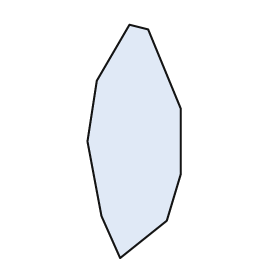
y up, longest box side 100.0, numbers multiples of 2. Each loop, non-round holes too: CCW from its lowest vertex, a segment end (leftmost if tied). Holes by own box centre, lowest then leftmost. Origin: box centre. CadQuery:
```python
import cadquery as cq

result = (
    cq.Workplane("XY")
    .moveTo(-6.0, -50.0)
    .lineTo(14.0, -34.0)
    .lineTo(20.0, -14.0)
    .lineTo(20.0, 14.0)
    .lineTo(6.0, 48.0)
    .lineTo(-2.0, 50.0)
    .lineTo(-16.0, 26.0)
    .lineTo(-20.0, 0.0)
    .lineTo(-14.0, -32.0)
    .close()
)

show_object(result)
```